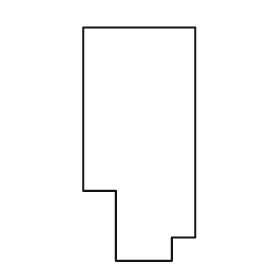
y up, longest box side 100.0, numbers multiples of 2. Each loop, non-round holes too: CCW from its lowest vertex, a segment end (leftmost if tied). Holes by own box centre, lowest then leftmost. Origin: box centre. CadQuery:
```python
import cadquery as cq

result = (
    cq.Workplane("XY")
    .moveTo(-10.0, -50.0)
    .lineTo(14.0, -50.0)
    .lineTo(14.0, -40.0)
    .lineTo(24.0, -40.0)
    .lineTo(24.0, 50.0)
    .lineTo(-24.0, 50.0)
    .lineTo(-24.0, -20.0)
    .lineTo(-10.0, -20.0)
    .close()
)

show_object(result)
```